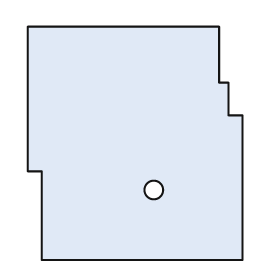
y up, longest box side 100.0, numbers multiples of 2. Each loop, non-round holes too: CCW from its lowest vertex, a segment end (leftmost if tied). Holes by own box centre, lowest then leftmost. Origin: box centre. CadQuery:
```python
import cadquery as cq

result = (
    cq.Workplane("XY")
    .moveTo(-40.0, -50.0)
    .lineTo(46.0, -50.0)
    .lineTo(46.0, 12.0)
    .lineTo(40.0, 12.0)
    .lineTo(40.0, 26.0)
    .lineTo(36.0, 26.0)
    .lineTo(36.0, 50.0)
    .lineTo(-46.0, 50.0)
    .lineTo(-46.0, -12.0)
    .lineTo(-40.0, -12.0)
    .close()
    .moveTo(8.0, -20.0)
    .circle(4.0)
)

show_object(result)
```